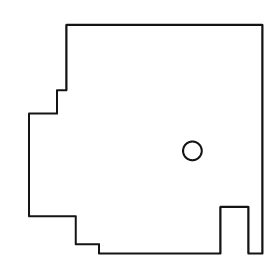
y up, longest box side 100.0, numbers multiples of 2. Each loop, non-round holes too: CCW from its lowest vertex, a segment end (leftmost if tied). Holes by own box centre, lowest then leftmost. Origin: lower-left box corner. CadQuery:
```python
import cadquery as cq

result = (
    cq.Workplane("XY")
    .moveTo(30.0, 0.0)
    .lineTo(82.0, 0.0)
    .lineTo(82.0, 20.0)
    .lineTo(94.0, 20.0)
    .lineTo(94.0, 0.0)
    .lineTo(100.0, 0.0)
    .lineTo(100.0, 98.0)
    .lineTo(16.0, 98.0)
    .lineTo(16.0, 70.0)
    .lineTo(12.0, 70.0)
    .lineTo(12.0, 60.0)
    .lineTo(0.0, 60.0)
    .lineTo(0.0, 16.0)
    .lineTo(20.0, 16.0)
    .lineTo(20.0, 4.0)
    .lineTo(30.0, 4.0)
    .close()
    .moveTo(70.0, 44.0)
    .circle(4.0)
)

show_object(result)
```